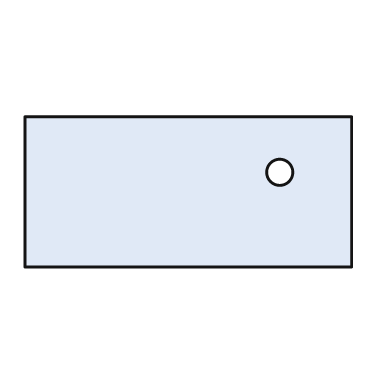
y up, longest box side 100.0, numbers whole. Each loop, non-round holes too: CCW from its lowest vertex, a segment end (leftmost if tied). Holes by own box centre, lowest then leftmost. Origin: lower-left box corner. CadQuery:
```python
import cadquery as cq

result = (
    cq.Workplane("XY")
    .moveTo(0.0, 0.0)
    .lineTo(100.0, 0.0)
    .lineTo(100.0, 46.0)
    .lineTo(0.0, 46.0)
    .close()
    .moveTo(78.0, 29.0)
    .circle(4.0)
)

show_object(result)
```